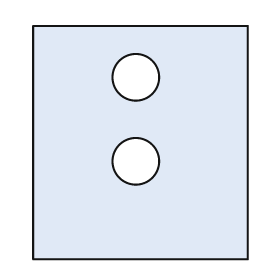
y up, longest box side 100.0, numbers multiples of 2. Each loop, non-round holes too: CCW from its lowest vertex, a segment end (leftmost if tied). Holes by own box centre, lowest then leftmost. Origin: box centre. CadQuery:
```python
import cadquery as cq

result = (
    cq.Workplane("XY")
    .moveTo(-46.0, -50.0)
    .lineTo(46.0, -50.0)
    .lineTo(46.0, 50.0)
    .lineTo(-46.0, 50.0)
    .close()
    .moveTo(-2.0, -8.0)
    .circle(10.0)
    .moveTo(-2.0, 28.0)
    .circle(10.0)
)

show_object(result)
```